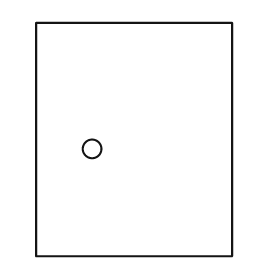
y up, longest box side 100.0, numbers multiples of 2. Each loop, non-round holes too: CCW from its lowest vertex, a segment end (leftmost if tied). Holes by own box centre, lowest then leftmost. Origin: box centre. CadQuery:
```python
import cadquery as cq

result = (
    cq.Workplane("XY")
    .moveTo(-42.0, -50.0)
    .lineTo(42.0, -50.0)
    .lineTo(42.0, 50.0)
    .lineTo(-42.0, 50.0)
    .close()
    .moveTo(-18.0, -4.0)
    .circle(4.0)
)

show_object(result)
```